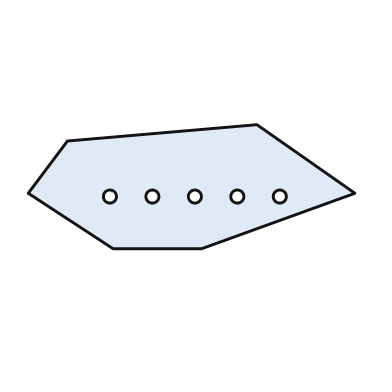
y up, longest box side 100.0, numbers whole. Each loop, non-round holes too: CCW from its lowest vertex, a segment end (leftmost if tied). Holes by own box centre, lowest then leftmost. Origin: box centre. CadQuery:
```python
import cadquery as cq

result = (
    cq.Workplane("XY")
    .moveTo(-24.0, -19.0)
    .lineTo(3.0, -19.0)
    .lineTo(50.0, -2.0)
    .lineTo(20.0, 19.0)
    .lineTo(-38.0, 14.0)
    .lineTo(-50.0, -2.0)
    .close()
    .moveTo(-25.0, -3.0)
    .circle(2.0)
    .moveTo(-12.0, -3.0)
    .circle(2.0)
    .moveTo(1.0, -3.0)
    .circle(2.0)
    .moveTo(14.0, -3.0)
    .circle(2.0)
    .moveTo(27.0, -3.0)
    .circle(2.0)
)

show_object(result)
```